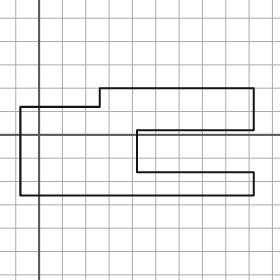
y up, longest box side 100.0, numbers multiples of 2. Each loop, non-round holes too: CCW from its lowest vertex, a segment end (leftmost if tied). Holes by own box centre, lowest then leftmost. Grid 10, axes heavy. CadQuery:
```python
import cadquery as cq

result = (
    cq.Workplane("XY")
    .moveTo(-8.0, -26.0)
    .lineTo(92.0, -26.0)
    .lineTo(92.0, -16.0)
    .lineTo(42.0, -16.0)
    .lineTo(42.0, 2.0)
    .lineTo(92.0, 2.0)
    .lineTo(92.0, 20.0)
    .lineTo(26.0, 20.0)
    .lineTo(26.0, 12.0)
    .lineTo(-8.0, 12.0)
    .close()
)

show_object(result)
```